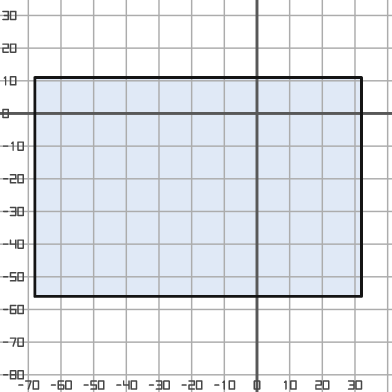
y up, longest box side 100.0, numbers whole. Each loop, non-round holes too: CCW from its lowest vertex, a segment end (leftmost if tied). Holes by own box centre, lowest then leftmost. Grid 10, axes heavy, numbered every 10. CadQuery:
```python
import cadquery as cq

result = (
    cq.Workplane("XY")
    .moveTo(-68.0, -56.0)
    .lineTo(32.0, -56.0)
    .lineTo(32.0, 11.0)
    .lineTo(-68.0, 11.0)
    .close()
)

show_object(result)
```